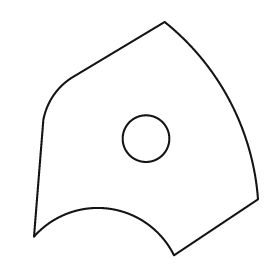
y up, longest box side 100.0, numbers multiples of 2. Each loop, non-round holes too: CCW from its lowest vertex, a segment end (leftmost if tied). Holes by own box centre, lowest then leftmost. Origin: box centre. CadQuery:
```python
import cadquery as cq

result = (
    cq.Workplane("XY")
    .moveTo(12.0, -50.0)
    .lineTo(48.0, -26.0)
    .threePointArc((36.0, 16.0), (8.0, 50.0))
    .lineTo(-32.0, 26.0)
    .threePointArc((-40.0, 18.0), (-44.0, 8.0))
    .lineTo(-48.0, -42.0)
    .threePointArc((-16.0, -30.0), (12.0, -50.0))
    .close()
    .moveTo(0.0, 0.0)
    .circle(10.0)
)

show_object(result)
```